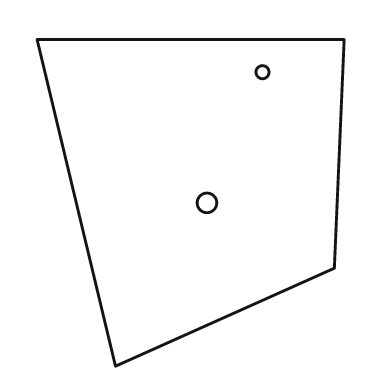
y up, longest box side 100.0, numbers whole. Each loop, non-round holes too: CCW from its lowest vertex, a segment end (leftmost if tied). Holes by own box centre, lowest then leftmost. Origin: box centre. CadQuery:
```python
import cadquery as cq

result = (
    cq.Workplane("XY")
    .moveTo(-23.0, -50.0)
    .lineTo(44.0, -20.0)
    .lineTo(47.0, 50.0)
    .lineTo(-47.0, 50.0)
    .close()
    .moveTo(5.0, 0.0)
    .circle(3.0)
    .moveTo(22.0, 40.0)
    .circle(2.0)
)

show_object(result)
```